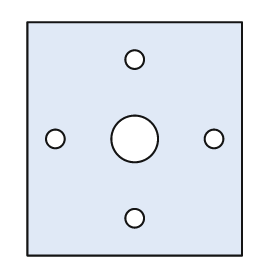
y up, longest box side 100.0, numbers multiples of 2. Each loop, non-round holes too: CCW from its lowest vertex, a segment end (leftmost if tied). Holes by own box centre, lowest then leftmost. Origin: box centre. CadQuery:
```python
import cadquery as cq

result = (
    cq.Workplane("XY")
    .moveTo(-46.0, -50.0)
    .lineTo(46.0, -50.0)
    .lineTo(46.0, 50.0)
    .lineTo(-46.0, 50.0)
    .close()
    .moveTo(0.0, -34.0)
    .circle(4.0)
    .moveTo(-34.0, 0.0)
    .circle(4.0)
    .moveTo(0.0, 0.0)
    .circle(10.0)
    .moveTo(34.0, 0.0)
    .circle(4.0)
    .moveTo(0.0, 34.0)
    .circle(4.0)
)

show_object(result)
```